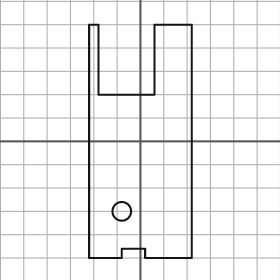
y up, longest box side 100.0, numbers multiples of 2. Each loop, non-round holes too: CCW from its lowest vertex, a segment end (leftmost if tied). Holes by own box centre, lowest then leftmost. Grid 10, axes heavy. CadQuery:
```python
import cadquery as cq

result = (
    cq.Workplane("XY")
    .moveTo(-22.0, -50.0)
    .lineTo(-8.0, -50.0)
    .lineTo(-8.0, -46.0)
    .lineTo(2.0, -46.0)
    .lineTo(2.0, -50.0)
    .lineTo(22.0, -50.0)
    .lineTo(22.0, 50.0)
    .lineTo(6.0, 50.0)
    .lineTo(6.0, 20.0)
    .lineTo(-18.0, 20.0)
    .lineTo(-18.0, 50.0)
    .lineTo(-22.0, 50.0)
    .close()
    .moveTo(-8.0, -30.0)
    .circle(4.0)
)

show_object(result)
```